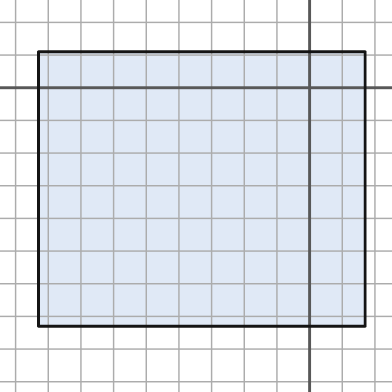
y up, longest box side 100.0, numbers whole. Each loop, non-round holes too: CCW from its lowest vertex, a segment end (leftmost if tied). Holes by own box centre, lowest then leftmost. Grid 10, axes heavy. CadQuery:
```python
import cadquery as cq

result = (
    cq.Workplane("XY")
    .moveTo(-83.0, -73.0)
    .lineTo(17.0, -73.0)
    .lineTo(17.0, 11.0)
    .lineTo(-83.0, 11.0)
    .close()
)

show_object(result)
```